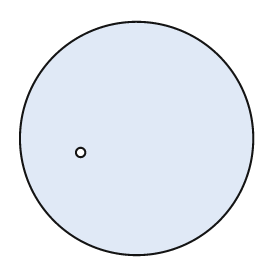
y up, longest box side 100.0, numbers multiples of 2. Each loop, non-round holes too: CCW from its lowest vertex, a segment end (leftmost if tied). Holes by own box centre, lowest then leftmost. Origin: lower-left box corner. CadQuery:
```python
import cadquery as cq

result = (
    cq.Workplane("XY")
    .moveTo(50.0, 50.0)
    .circle(50.0)
    .moveTo(26.0, 44.0)
    .circle(2.0)
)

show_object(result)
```